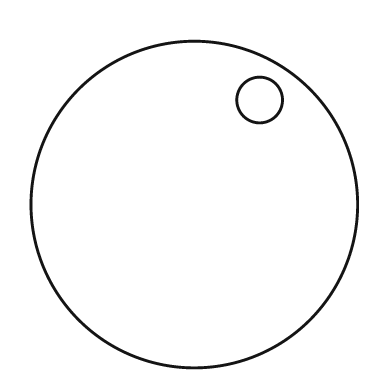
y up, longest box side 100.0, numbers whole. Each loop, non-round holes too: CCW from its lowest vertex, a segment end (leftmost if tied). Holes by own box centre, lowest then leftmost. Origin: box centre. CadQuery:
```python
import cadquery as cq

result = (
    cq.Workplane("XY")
    .moveTo(0.0, 0.0)
    .circle(50.0)
    .moveTo(20.0, 32.0)
    .circle(7.0)
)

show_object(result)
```